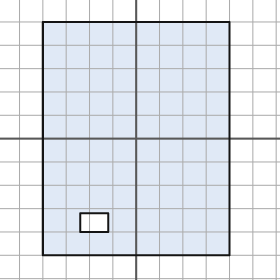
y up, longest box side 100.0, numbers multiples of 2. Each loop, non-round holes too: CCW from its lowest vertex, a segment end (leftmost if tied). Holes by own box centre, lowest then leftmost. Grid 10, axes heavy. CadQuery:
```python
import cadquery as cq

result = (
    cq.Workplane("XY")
    .moveTo(-40.0, -50.0)
    .lineTo(40.0, -50.0)
    .lineTo(40.0, 50.0)
    .lineTo(-40.0, 50.0)
    .close()
    .moveTo(-24.0, -40.0)
    .lineTo(-12.0, -40.0)
    .lineTo(-12.0, -32.0)
    .lineTo(-24.0, -32.0)
    .close()
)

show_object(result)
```